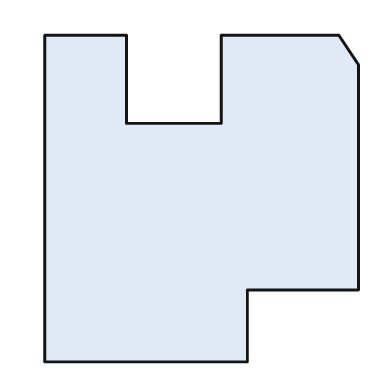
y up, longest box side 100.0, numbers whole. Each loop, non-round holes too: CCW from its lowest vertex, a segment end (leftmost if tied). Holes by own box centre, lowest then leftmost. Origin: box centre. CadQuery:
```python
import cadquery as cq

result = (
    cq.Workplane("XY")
    .moveTo(-48.0, -50.0)
    .lineTo(14.0, -50.0)
    .lineTo(14.0, -28.0)
    .lineTo(48.0, -28.0)
    .lineTo(48.0, 41.0)
    .lineTo(42.0, 50.0)
    .lineTo(6.0, 50.0)
    .lineTo(6.0, 23.0)
    .lineTo(-23.0, 23.0)
    .lineTo(-23.0, 50.0)
    .lineTo(-48.0, 50.0)
    .close()
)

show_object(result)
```